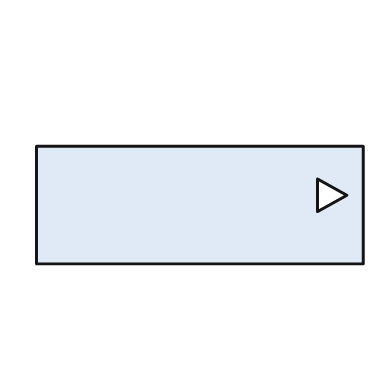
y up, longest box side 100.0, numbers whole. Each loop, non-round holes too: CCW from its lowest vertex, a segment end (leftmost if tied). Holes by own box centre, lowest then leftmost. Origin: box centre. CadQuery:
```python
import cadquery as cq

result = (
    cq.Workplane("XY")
    .moveTo(-50.0, -18.0)
    .lineTo(50.0, -18.0)
    .lineTo(50.0, 18.0)
    .lineTo(-50.0, 18.0)
    .close()
    .moveTo(36.0, -2.0)
    .lineTo(45.0, 3.0)
    .lineTo(36.0, 8.0)
    .close()
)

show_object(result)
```